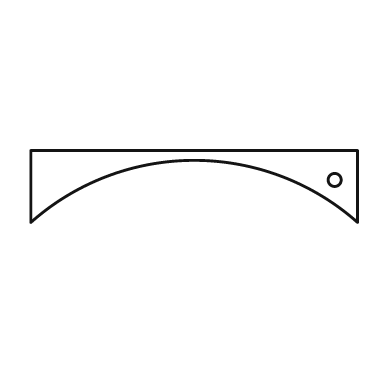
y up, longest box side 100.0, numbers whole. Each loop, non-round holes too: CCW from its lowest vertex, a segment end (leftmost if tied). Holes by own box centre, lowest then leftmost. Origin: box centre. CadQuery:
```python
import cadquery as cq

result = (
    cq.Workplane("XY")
    .moveTo(-50.0, -11.0)
    .threePointArc((0.0, 8.0), (50.0, -11.0))
    .lineTo(50.0, 11.0)
    .lineTo(-50.0, 11.0)
    .close()
    .moveTo(43.0, 2.0)
    .circle(2.0)
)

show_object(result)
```